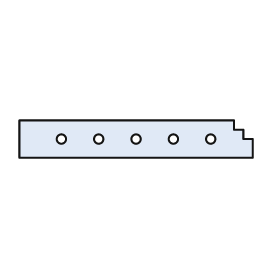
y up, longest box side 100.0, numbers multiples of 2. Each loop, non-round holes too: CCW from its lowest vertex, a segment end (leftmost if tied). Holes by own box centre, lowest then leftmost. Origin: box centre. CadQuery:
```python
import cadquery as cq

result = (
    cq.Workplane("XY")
    .moveTo(-50.0, -8.0)
    .lineTo(50.0, -8.0)
    .lineTo(50.0, 0.0)
    .lineTo(46.0, 0.0)
    .lineTo(46.0, 4.0)
    .lineTo(42.0, 4.0)
    .lineTo(42.0, 8.0)
    .lineTo(-50.0, 8.0)
    .close()
    .moveTo(-32.0, 0.0)
    .circle(2.0)
    .moveTo(-16.0, 0.0)
    .circle(2.0)
    .moveTo(0.0, 0.0)
    .circle(2.0)
    .moveTo(16.0, 0.0)
    .circle(2.0)
    .moveTo(32.0, 0.0)
    .circle(2.0)
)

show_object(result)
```